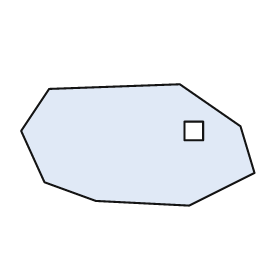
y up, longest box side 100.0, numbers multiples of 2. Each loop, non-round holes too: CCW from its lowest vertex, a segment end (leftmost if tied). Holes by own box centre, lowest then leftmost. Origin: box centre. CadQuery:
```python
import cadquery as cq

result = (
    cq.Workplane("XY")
    .moveTo(22.0, -26.0)
    .lineTo(50.0, -12.0)
    .lineTo(44.0, 8.0)
    .lineTo(18.0, 26.0)
    .lineTo(-38.0, 24.0)
    .lineTo(-50.0, 6.0)
    .lineTo(-40.0, -16.0)
    .lineTo(-18.0, -24.0)
    .close()
    .moveTo(20.0, 2.0)
    .lineTo(28.0, 2.0)
    .lineTo(28.0, 10.0)
    .lineTo(20.0, 10.0)
    .close()
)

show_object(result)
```